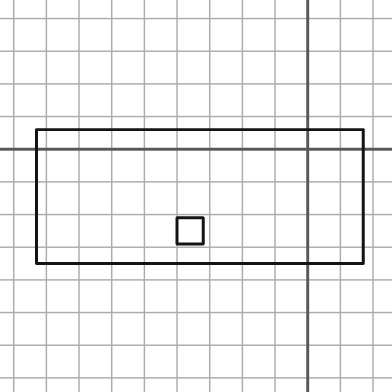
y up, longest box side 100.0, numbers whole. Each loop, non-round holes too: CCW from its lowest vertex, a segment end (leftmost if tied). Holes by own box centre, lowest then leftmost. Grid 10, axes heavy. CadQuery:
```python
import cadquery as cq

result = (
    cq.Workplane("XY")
    .moveTo(-83.0, -35.0)
    .lineTo(17.0, -35.0)
    .lineTo(17.0, 6.0)
    .lineTo(-83.0, 6.0)
    .close()
    .moveTo(-40.0, -29.0)
    .lineTo(-32.0, -29.0)
    .lineTo(-32.0, -21.0)
    .lineTo(-40.0, -21.0)
    .close()
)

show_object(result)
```